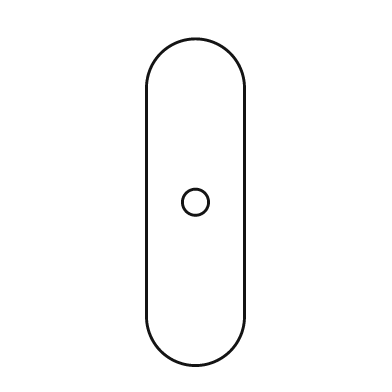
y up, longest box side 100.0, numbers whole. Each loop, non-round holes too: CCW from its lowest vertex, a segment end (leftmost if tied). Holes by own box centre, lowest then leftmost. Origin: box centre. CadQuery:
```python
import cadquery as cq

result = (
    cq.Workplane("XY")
    .moveTo(-15.0, -35.0)
    .threePointArc((0.0, -50.0), (15.0, -35.0))
    .lineTo(15.0, 35.0)
    .threePointArc((0.0, 50.0), (-15.0, 35.0))
    .close()
    .moveTo(0.0, 0.0)
    .circle(4.0)
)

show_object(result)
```